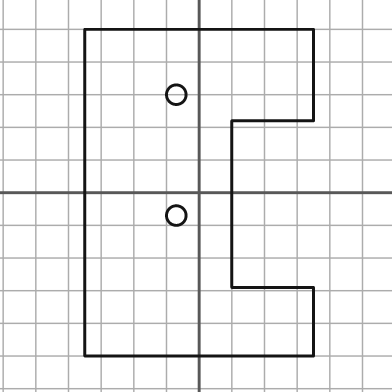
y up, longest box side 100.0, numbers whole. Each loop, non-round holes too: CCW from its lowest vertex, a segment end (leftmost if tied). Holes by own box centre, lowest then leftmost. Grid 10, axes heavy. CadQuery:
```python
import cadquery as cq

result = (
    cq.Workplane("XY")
    .moveTo(-35.0, -50.0)
    .lineTo(35.0, -50.0)
    .lineTo(35.0, -29.0)
    .lineTo(10.0, -29.0)
    .lineTo(10.0, 22.0)
    .lineTo(35.0, 22.0)
    .lineTo(35.0, 50.0)
    .lineTo(-35.0, 50.0)
    .close()
    .moveTo(-7.0, -7.0)
    .circle(3.0)
    .moveTo(-7.0, 30.0)
    .circle(3.0)
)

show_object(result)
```